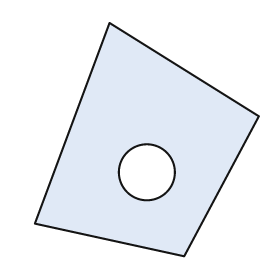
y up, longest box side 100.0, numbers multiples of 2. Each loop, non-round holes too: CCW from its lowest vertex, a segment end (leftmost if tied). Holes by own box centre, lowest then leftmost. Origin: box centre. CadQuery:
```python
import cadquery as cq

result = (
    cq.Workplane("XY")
    .moveTo(16.0, -50.0)
    .lineTo(48.0, 10.0)
    .lineTo(-16.0, 50.0)
    .lineTo(-48.0, -36.0)
    .close()
    .moveTo(0.0, -14.0)
    .circle(12.0)
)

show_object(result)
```